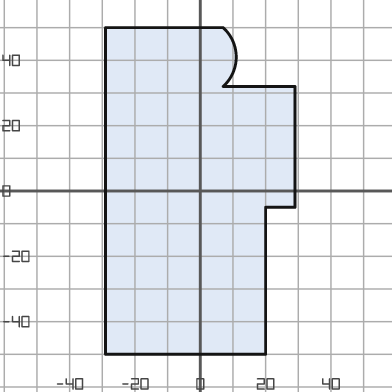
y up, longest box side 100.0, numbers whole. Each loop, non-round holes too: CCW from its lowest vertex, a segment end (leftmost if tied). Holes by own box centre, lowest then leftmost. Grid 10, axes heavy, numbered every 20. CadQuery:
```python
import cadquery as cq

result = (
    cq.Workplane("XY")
    .moveTo(-29.0, -50.0)
    .lineTo(20.0, -50.0)
    .lineTo(20.0, -5.0)
    .lineTo(29.0, -5.0)
    .lineTo(29.0, 32.0)
    .lineTo(7.0, 32.0)
    .threePointArc((11.0, 41.0), (7.0, 50.0))
    .lineTo(-29.0, 50.0)
    .close()
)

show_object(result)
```